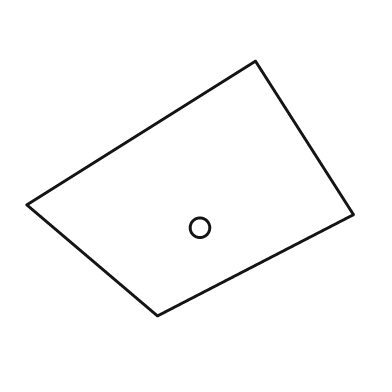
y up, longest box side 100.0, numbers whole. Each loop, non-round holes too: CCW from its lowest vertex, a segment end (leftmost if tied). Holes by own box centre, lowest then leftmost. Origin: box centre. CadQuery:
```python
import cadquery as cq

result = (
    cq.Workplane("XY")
    .moveTo(-10.0, -39.0)
    .lineTo(50.0, -8.0)
    .lineTo(20.0, 39.0)
    .lineTo(-50.0, -5.0)
    .close()
    .moveTo(3.0, -12.0)
    .circle(3.0)
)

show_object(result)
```